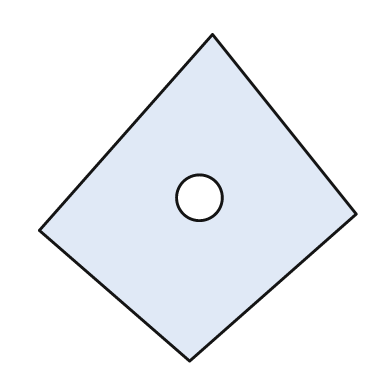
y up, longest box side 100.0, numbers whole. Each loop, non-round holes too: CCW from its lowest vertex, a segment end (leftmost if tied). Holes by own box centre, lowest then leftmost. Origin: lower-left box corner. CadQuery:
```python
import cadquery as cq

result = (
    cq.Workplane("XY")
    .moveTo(46.0, 0.0)
    .lineTo(97.0, 45.0)
    .lineTo(53.0, 100.0)
    .lineTo(0.0, 40.0)
    .close()
    .moveTo(49.0, 50.0)
    .circle(7.0)
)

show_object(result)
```